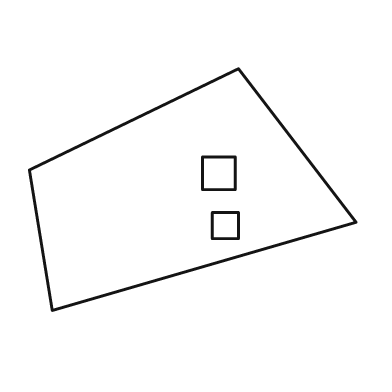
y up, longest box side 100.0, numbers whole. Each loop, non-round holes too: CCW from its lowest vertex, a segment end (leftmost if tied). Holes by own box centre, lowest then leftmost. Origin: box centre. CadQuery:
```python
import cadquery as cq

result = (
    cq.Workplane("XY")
    .moveTo(-43.0, -37.0)
    .lineTo(50.0, -10.0)
    .lineTo(14.0, 37.0)
    .lineTo(-50.0, 6.0)
    .close()
    .moveTo(6.0, -15.0)
    .lineTo(14.0, -15.0)
    .lineTo(14.0, -7.0)
    .lineTo(6.0, -7.0)
    .close()
    .moveTo(3.0, 0.0)
    .lineTo(13.0, 0.0)
    .lineTo(13.0, 10.0)
    .lineTo(3.0, 10.0)
    .close()
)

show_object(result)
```